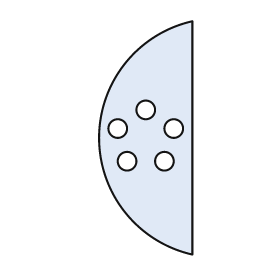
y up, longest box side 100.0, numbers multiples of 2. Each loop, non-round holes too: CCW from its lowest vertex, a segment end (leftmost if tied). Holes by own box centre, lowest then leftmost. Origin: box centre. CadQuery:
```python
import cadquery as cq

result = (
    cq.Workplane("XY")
    .moveTo(20.0, -50.0)
    .lineTo(20.0, 50.0)
    .threePointArc((-20.0, 0.0), (20.0, -50.0))
    .close()
    .moveTo(-8.0, -10.0)
    .circle(4.0)
    .moveTo(8.0, -10.0)
    .circle(4.0)
    .moveTo(-12.0, 4.0)
    .circle(4.0)
    .moveTo(12.0, 4.0)
    .circle(4.0)
    .moveTo(0.0, 12.0)
    .circle(4.0)
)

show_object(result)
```